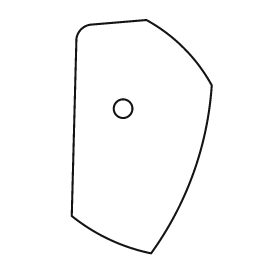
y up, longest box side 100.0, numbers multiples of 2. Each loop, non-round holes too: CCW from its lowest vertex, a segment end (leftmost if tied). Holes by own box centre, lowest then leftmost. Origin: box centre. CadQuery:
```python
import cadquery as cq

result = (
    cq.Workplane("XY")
    .moveTo(4.0, -50.0)
    .threePointArc((22.0, -16.0), (30.0, 22.0))
    .threePointArc((18.0, 38.0), (2.0, 50.0))
    .lineTo(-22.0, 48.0)
    .threePointArc((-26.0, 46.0), (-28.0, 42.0))
    .lineTo(-30.0, -34.0)
    .threePointArc((-14.0, -44.0), (4.0, -50.0))
    .close()
    .moveTo(-8.0, 12.0)
    .circle(4.0)
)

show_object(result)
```